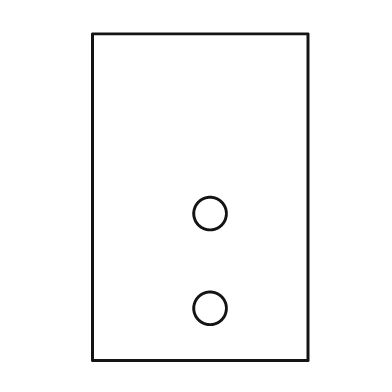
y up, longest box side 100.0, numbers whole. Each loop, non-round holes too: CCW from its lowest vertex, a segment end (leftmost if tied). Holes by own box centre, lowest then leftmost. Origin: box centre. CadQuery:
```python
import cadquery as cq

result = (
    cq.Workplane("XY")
    .moveTo(-33.0, -50.0)
    .lineTo(33.0, -50.0)
    .lineTo(33.0, 50.0)
    .lineTo(-33.0, 50.0)
    .close()
    .moveTo(3.0, -34.0)
    .circle(5.0)
    .moveTo(3.0, -5.0)
    .circle(5.0)
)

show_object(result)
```